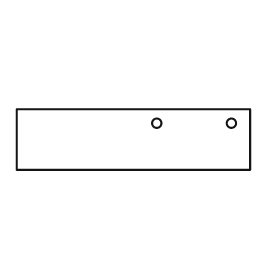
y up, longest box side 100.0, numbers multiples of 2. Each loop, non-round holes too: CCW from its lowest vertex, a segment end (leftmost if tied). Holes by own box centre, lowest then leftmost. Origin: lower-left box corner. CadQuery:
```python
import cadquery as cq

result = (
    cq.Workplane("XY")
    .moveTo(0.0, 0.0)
    .lineTo(100.0, 0.0)
    .lineTo(100.0, 26.0)
    .lineTo(0.0, 26.0)
    .close()
    .moveTo(60.0, 20.0)
    .circle(2.0)
    .moveTo(92.0, 20.0)
    .circle(2.0)
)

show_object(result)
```